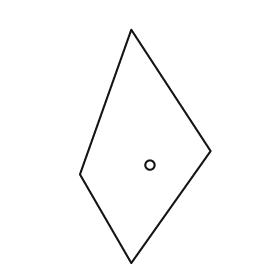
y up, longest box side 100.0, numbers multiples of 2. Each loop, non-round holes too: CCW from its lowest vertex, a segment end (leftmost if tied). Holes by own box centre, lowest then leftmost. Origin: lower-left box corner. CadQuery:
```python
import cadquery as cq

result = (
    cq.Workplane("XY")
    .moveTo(22.0, 0.0)
    .lineTo(56.0, 48.0)
    .lineTo(22.0, 100.0)
    .lineTo(0.0, 38.0)
    .close()
    .moveTo(30.0, 42.0)
    .circle(2.0)
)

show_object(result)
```